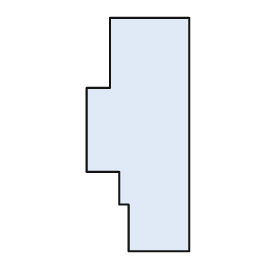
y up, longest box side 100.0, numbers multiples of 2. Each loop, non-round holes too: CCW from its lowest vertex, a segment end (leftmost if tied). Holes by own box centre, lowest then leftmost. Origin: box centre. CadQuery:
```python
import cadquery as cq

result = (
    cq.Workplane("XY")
    .moveTo(-4.0, -50.0)
    .lineTo(22.0, -50.0)
    .lineTo(22.0, 50.0)
    .lineTo(-12.0, 50.0)
    .lineTo(-12.0, 20.0)
    .lineTo(-22.0, 20.0)
    .lineTo(-22.0, -16.0)
    .lineTo(-8.0, -16.0)
    .lineTo(-8.0, -30.0)
    .lineTo(-4.0, -30.0)
    .close()
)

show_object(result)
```